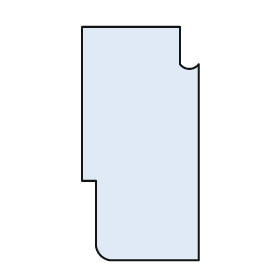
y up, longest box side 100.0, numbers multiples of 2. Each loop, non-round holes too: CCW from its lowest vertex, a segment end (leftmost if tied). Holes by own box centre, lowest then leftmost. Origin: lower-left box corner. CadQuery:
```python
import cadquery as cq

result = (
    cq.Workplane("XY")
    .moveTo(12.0, 0.0)
    .lineTo(50.0, 0.0)
    .lineTo(50.0, 84.0)
    .threePointArc((46.0, 82.0), (42.0, 84.0))
    .lineTo(42.0, 100.0)
    .lineTo(0.0, 100.0)
    .lineTo(0.0, 34.0)
    .lineTo(6.0, 34.0)
    .lineTo(6.0, 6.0)
    .threePointArc((8.0, 2.0), (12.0, 0.0))
    .close()
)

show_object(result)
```